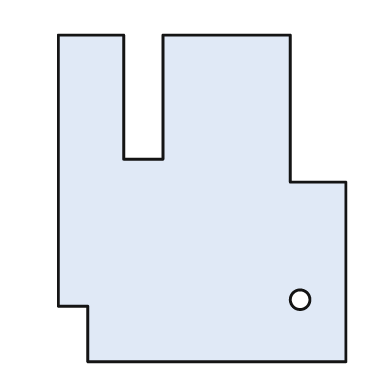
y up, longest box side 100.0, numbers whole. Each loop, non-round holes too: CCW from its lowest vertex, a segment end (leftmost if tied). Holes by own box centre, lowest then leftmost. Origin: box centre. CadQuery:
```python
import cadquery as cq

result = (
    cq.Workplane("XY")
    .moveTo(-35.0, -50.0)
    .lineTo(44.0, -50.0)
    .lineTo(44.0, 5.0)
    .lineTo(27.0, 5.0)
    .lineTo(27.0, 50.0)
    .lineTo(-12.0, 50.0)
    .lineTo(-12.0, 12.0)
    .lineTo(-24.0, 12.0)
    .lineTo(-24.0, 50.0)
    .lineTo(-44.0, 50.0)
    .lineTo(-44.0, -33.0)
    .lineTo(-35.0, -33.0)
    .close()
    .moveTo(30.0, -31.0)
    .circle(3.0)
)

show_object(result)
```